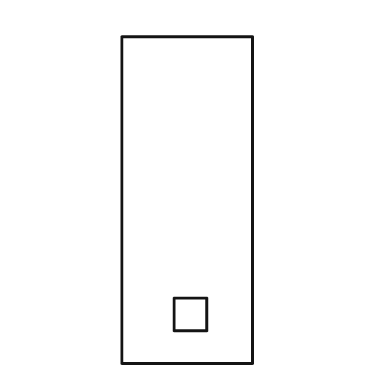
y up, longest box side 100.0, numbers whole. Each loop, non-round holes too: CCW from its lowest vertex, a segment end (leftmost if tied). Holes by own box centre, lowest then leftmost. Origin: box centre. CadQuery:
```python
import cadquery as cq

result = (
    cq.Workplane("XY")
    .moveTo(-20.0, -50.0)
    .lineTo(20.0, -50.0)
    .lineTo(20.0, 50.0)
    .lineTo(-20.0, 50.0)
    .close()
    .moveTo(-4.0, -40.0)
    .lineTo(6.0, -40.0)
    .lineTo(6.0, -30.0)
    .lineTo(-4.0, -30.0)
    .close()
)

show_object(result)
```